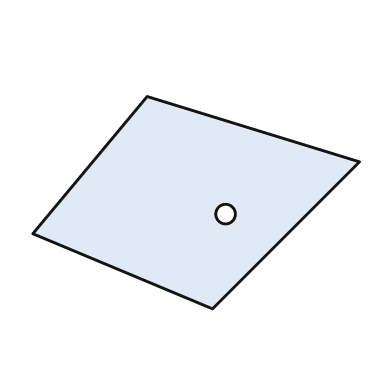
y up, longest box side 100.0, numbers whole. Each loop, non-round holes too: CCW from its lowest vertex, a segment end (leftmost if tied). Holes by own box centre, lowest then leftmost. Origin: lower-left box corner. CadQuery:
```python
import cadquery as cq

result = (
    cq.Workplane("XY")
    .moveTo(55.0, 0.0)
    .lineTo(100.0, 45.0)
    .lineTo(35.0, 65.0)
    .lineTo(0.0, 23.0)
    .close()
    .moveTo(59.0, 29.0)
    .circle(3.0)
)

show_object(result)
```